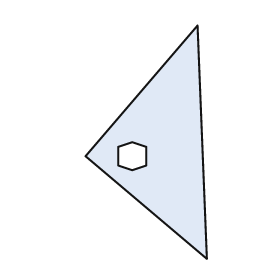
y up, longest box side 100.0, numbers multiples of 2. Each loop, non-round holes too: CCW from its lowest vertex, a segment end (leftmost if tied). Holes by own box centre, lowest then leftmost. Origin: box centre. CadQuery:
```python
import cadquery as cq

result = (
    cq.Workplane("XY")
    .moveTo(26.0, -50.0)
    .lineTo(22.0, 50.0)
    .lineTo(-26.0, -6.0)
    .close()
    .moveTo(-6.0, -12.0)
    .lineTo(0.0, -10.0)
    .lineTo(0.0, -2.0)
    .lineTo(-6.0, 0.0)
    .lineTo(-12.0, -2.0)
    .lineTo(-12.0, -10.0)
    .close()
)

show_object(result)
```